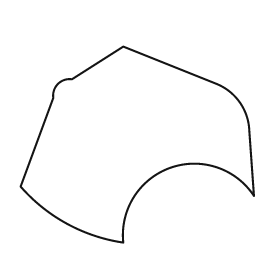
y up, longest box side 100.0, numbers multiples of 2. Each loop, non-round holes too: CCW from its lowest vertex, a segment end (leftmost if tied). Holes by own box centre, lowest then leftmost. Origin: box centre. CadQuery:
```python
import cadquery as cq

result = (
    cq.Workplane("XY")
    .moveTo(-6.0, -42.0)
    .threePointArc((14.0, -10.0), (50.0, -22.0))
    .lineTo(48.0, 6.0)
    .threePointArc((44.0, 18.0), (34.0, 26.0))
    .lineTo(-6.0, 42.0)
    .lineTo(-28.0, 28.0)
    .threePointArc((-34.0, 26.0), (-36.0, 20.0))
    .lineTo(-50.0, -18.0)
    .threePointArc((-30.0, -34.0), (-6.0, -42.0))
    .close()
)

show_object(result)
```